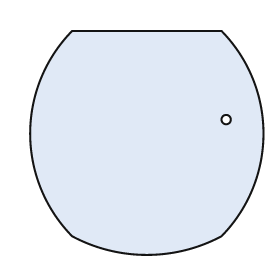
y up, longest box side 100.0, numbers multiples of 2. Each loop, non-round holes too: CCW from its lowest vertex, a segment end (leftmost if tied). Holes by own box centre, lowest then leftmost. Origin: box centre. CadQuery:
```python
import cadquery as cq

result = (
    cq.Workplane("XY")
    .moveTo(-32.0, -40.0)
    .threePointArc((0.0, -48.0), (32.0, -40.0))
    .threePointArc((50.0, 4.0), (32.0, 48.0))
    .lineTo(-32.0, 48.0)
    .threePointArc((-50.0, 4.0), (-32.0, -40.0))
    .close()
    .moveTo(34.0, 10.0)
    .circle(2.0)
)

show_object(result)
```